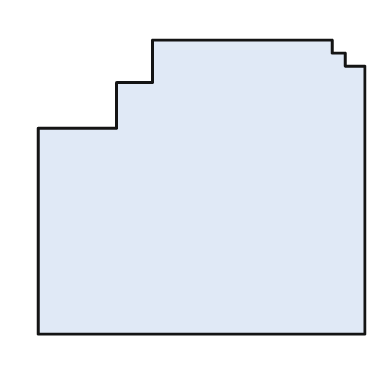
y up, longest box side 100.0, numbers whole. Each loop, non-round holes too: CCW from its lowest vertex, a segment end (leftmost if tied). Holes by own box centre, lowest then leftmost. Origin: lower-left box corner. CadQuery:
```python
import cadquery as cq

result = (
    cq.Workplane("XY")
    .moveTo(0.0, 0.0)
    .lineTo(100.0, 0.0)
    .lineTo(100.0, 82.0)
    .lineTo(94.0, 82.0)
    .lineTo(94.0, 86.0)
    .lineTo(90.0, 86.0)
    .lineTo(90.0, 90.0)
    .lineTo(35.0, 90.0)
    .lineTo(35.0, 77.0)
    .lineTo(24.0, 77.0)
    .lineTo(24.0, 63.0)
    .lineTo(0.0, 63.0)
    .close()
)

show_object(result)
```